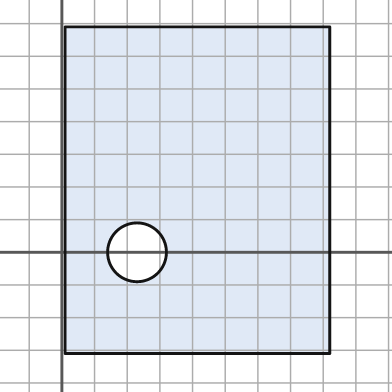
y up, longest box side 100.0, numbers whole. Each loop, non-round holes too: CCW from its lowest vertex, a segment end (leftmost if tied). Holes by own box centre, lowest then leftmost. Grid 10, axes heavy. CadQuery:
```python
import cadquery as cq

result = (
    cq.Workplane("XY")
    .moveTo(1.0, -31.0)
    .lineTo(82.0, -31.0)
    .lineTo(82.0, 69.0)
    .lineTo(1.0, 69.0)
    .close()
    .moveTo(23.0, 0.0)
    .circle(9.0)
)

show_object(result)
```